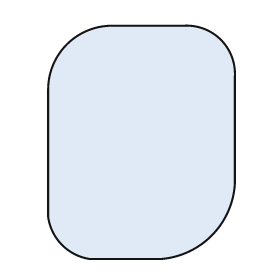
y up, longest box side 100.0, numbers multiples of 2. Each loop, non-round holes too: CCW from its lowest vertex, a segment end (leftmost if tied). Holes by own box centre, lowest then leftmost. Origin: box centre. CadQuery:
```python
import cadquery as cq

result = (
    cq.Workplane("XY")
    .moveTo(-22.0, -50.0)
    .lineTo(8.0, -50.0)
    .threePointArc((30.0, -40.0), (40.0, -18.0))
    .lineTo(40.0, 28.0)
    .threePointArc((34.0, 44.0), (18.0, 50.0))
    .lineTo(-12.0, 50.0)
    .threePointArc((-32.0, 42.0), (-40.0, 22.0))
    .lineTo(-40.0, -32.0)
    .threePointArc((-34.0, -44.0), (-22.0, -50.0))
    .close()
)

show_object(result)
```